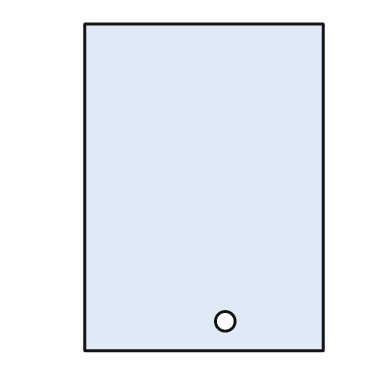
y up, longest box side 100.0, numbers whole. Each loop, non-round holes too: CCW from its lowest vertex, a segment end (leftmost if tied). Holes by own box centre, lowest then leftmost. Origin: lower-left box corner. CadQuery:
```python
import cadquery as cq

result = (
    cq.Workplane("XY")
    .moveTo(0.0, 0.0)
    .lineTo(73.0, 0.0)
    .lineTo(73.0, 100.0)
    .lineTo(0.0, 100.0)
    .close()
    .moveTo(43.0, 9.0)
    .circle(3.0)
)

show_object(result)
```